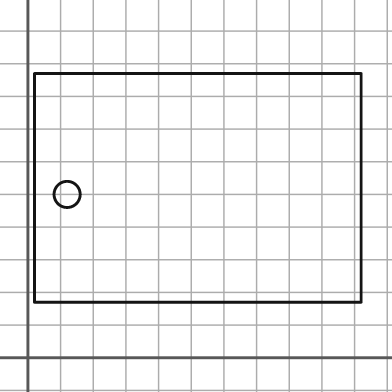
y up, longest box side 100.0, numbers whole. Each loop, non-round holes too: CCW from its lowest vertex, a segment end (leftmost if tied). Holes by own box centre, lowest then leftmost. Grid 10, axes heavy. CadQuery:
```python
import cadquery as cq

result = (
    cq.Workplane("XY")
    .moveTo(2.0, 17.0)
    .lineTo(102.0, 17.0)
    .lineTo(102.0, 87.0)
    .lineTo(2.0, 87.0)
    .close()
    .moveTo(12.0, 50.0)
    .circle(4.0)
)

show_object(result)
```